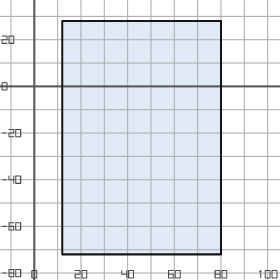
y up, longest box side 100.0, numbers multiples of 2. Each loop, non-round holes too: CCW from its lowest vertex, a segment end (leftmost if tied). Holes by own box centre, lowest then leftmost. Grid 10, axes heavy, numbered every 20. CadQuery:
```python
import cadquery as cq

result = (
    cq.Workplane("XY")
    .moveTo(12.0, -72.0)
    .lineTo(80.0, -72.0)
    .lineTo(80.0, 28.0)
    .lineTo(12.0, 28.0)
    .close()
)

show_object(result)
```